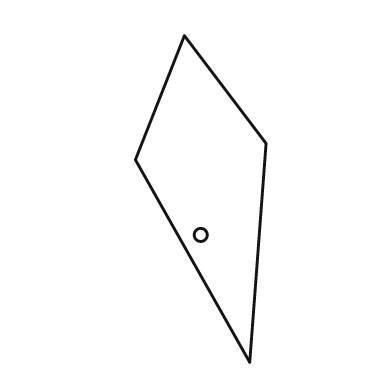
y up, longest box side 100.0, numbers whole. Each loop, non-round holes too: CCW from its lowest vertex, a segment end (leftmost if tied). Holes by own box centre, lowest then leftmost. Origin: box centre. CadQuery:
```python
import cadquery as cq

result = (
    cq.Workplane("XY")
    .moveTo(15.0, -50.0)
    .lineTo(20.0, 17.0)
    .lineTo(-5.0, 50.0)
    .lineTo(-20.0, 12.0)
    .close()
    .moveTo(0.0, -11.0)
    .circle(2.0)
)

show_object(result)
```